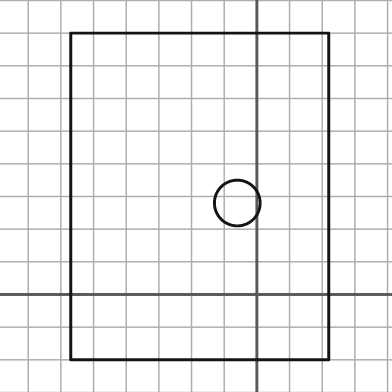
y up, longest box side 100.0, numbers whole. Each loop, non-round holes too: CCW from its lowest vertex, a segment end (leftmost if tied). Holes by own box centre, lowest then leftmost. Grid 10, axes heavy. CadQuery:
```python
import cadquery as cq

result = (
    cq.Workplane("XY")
    .moveTo(-57.0, -20.0)
    .lineTo(22.0, -20.0)
    .lineTo(22.0, 80.0)
    .lineTo(-57.0, 80.0)
    .close()
    .moveTo(-6.0, 28.0)
    .circle(7.0)
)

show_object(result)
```